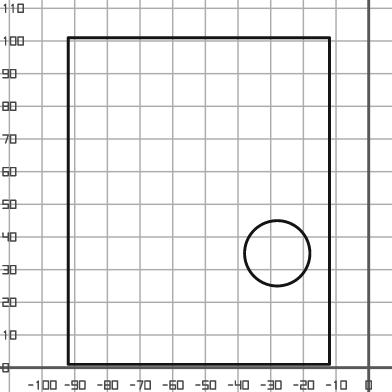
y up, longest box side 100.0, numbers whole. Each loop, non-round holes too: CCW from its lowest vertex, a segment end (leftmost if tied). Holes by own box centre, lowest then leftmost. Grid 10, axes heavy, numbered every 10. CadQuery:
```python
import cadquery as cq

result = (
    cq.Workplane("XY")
    .moveTo(-92.0, 1.0)
    .lineTo(-12.0, 1.0)
    .lineTo(-12.0, 101.0)
    .lineTo(-92.0, 101.0)
    .close()
    .moveTo(-28.0, 35.0)
    .circle(10.0)
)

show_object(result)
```